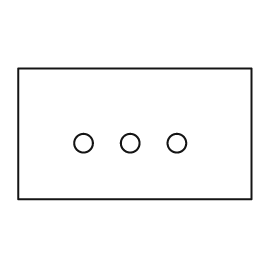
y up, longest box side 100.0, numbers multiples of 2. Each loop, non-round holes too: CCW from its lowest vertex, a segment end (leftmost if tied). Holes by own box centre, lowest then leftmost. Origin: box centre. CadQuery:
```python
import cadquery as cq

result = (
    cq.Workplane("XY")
    .moveTo(-50.0, -28.0)
    .lineTo(50.0, -28.0)
    .lineTo(50.0, 28.0)
    .lineTo(-50.0, 28.0)
    .close()
    .moveTo(-22.0, -4.0)
    .circle(4.0)
    .moveTo(-2.0, -4.0)
    .circle(4.0)
    .moveTo(18.0, -4.0)
    .circle(4.0)
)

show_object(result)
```